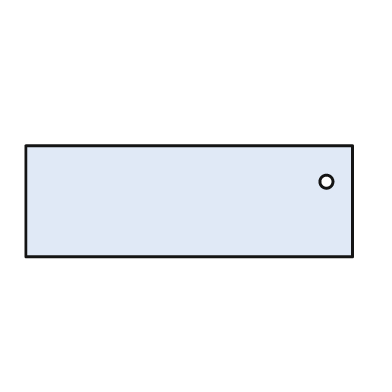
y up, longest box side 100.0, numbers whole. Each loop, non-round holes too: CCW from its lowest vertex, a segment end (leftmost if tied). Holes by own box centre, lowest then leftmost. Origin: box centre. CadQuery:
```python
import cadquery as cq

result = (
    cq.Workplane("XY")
    .moveTo(-50.0, -17.0)
    .lineTo(50.0, -17.0)
    .lineTo(50.0, 17.0)
    .lineTo(-50.0, 17.0)
    .close()
    .moveTo(42.0, 6.0)
    .circle(2.0)
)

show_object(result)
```